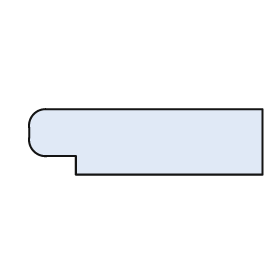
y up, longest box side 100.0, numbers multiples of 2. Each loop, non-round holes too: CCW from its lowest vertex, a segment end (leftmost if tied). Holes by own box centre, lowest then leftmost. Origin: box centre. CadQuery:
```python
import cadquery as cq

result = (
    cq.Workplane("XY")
    .moveTo(-30.0, -14.0)
    .lineTo(50.0, -14.0)
    .lineTo(50.0, 14.0)
    .lineTo(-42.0, 14.0)
    .threePointArc((-48.0, 12.0), (-50.0, 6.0))
    .lineTo(-50.0, 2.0)
    .threePointArc((-48.0, -4.0), (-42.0, -6.0))
    .lineTo(-30.0, -6.0)
    .close()
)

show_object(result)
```